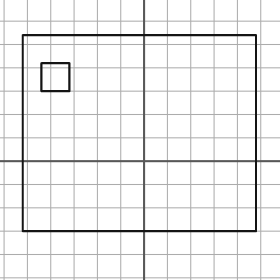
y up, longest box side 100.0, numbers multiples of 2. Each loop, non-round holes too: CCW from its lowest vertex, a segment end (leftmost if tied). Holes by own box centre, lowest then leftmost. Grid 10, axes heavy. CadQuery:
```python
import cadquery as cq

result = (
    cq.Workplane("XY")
    .moveTo(-52.0, -30.0)
    .lineTo(48.0, -30.0)
    .lineTo(48.0, 54.0)
    .lineTo(-52.0, 54.0)
    .close()
    .moveTo(-44.0, 30.0)
    .lineTo(-32.0, 30.0)
    .lineTo(-32.0, 42.0)
    .lineTo(-44.0, 42.0)
    .close()
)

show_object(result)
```